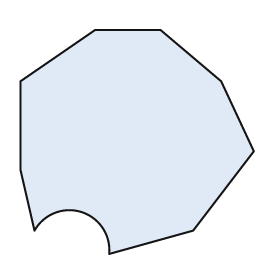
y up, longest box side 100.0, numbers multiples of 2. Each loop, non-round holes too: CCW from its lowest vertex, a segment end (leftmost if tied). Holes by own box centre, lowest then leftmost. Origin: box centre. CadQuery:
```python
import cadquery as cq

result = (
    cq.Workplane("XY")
    .moveTo(-12.0, -48.0)
    .lineTo(24.0, -38.0)
    .lineTo(50.0, -4.0)
    .lineTo(36.0, 26.0)
    .lineTo(10.0, 48.0)
    .lineTo(-18.0, 48.0)
    .lineTo(-50.0, 26.0)
    .lineTo(-50.0, -12.0)
    .lineTo(-44.0, -38.0)
    .threePointArc((-24.0, -30.0), (-12.0, -48.0))
    .close()
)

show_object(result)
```